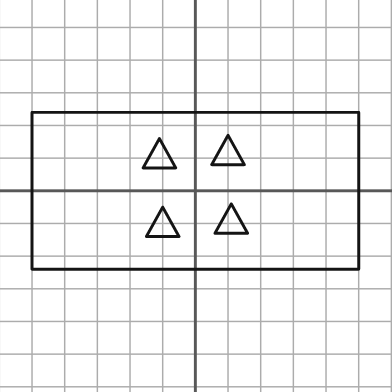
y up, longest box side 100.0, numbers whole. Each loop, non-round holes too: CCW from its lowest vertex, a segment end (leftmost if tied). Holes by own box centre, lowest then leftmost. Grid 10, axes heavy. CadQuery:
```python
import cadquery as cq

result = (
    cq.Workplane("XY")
    .moveTo(-50.0, -24.0)
    .lineTo(50.0, -24.0)
    .lineTo(50.0, 24.0)
    .lineTo(-50.0, 24.0)
    .close()
    .moveTo(-15.0, -14.0)
    .lineTo(-5.0, -14.0)
    .lineTo(-10.0, -5.0)
    .close()
    .moveTo(6.0, -13.0)
    .lineTo(16.0, -13.0)
    .lineTo(11.0, -4.0)
    .close()
    .moveTo(-16.0, 7.0)
    .lineTo(-6.0, 7.0)
    .lineTo(-11.0, 16.0)
    .close()
    .moveTo(5.0, 8.0)
    .lineTo(15.0, 8.0)
    .lineTo(10.0, 17.0)
    .close()
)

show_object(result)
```